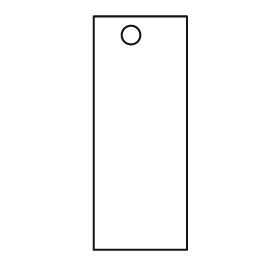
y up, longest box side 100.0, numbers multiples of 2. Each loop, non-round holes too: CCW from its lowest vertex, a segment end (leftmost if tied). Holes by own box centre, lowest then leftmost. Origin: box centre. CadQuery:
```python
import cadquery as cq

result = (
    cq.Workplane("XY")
    .moveTo(-20.0, -50.0)
    .lineTo(20.0, -50.0)
    .lineTo(20.0, 50.0)
    .lineTo(-20.0, 50.0)
    .close()
    .moveTo(-4.0, 42.0)
    .circle(4.0)
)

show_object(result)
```